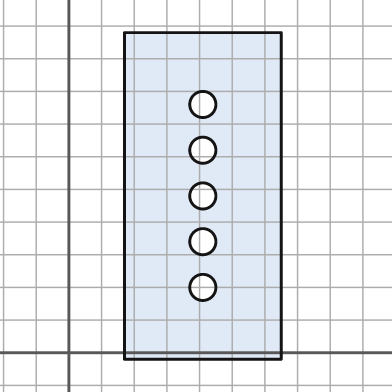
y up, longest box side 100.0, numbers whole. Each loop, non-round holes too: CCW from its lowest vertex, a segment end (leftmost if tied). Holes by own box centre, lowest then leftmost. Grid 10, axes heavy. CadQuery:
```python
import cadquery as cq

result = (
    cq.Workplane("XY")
    .moveTo(17.0, -2.0)
    .lineTo(65.0, -2.0)
    .lineTo(65.0, 98.0)
    .lineTo(17.0, 98.0)
    .close()
    .moveTo(41.0, 20.0)
    .circle(4.0)
    .moveTo(41.0, 34.0)
    .circle(4.0)
    .moveTo(41.0, 48.0)
    .circle(4.0)
    .moveTo(41.0, 62.0)
    .circle(4.0)
    .moveTo(41.0, 76.0)
    .circle(4.0)
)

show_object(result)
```